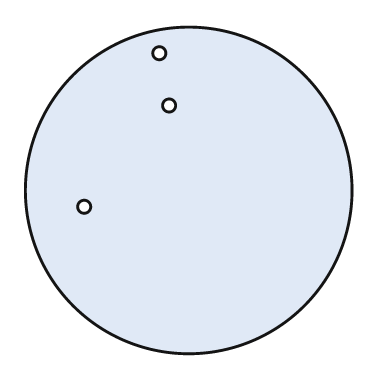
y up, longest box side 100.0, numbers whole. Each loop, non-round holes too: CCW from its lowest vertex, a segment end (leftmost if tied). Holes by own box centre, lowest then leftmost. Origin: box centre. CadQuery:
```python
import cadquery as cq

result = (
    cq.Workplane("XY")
    .moveTo(0.0, 0.0)
    .circle(50.0)
    .moveTo(-32.0, -5.0)
    .circle(2.0)
    .moveTo(-6.0, 26.0)
    .circle(2.0)
    .moveTo(-9.0, 42.0)
    .circle(2.0)
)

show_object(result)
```